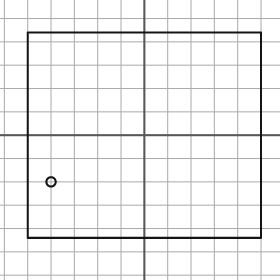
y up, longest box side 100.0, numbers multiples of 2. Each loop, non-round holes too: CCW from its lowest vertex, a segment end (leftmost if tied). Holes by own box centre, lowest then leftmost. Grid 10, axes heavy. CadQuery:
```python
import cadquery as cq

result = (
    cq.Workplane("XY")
    .moveTo(-50.0, -44.0)
    .lineTo(50.0, -44.0)
    .lineTo(50.0, 44.0)
    .lineTo(-50.0, 44.0)
    .close()
    .moveTo(-40.0, -20.0)
    .circle(2.0)
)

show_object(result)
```